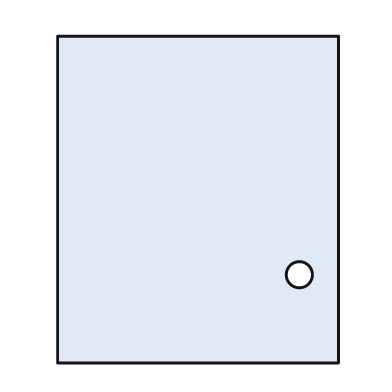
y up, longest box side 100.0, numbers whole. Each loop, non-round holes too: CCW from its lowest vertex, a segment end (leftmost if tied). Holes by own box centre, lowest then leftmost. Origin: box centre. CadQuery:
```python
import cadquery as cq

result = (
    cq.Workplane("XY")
    .moveTo(-43.0, -50.0)
    .lineTo(43.0, -50.0)
    .lineTo(43.0, 50.0)
    .lineTo(-43.0, 50.0)
    .close()
    .moveTo(31.0, -23.0)
    .circle(4.0)
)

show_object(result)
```